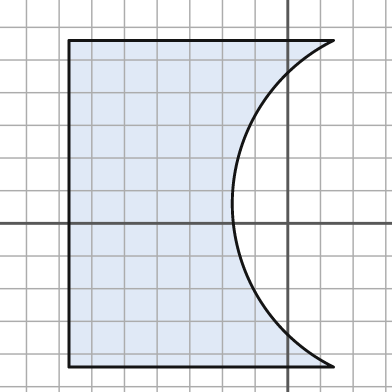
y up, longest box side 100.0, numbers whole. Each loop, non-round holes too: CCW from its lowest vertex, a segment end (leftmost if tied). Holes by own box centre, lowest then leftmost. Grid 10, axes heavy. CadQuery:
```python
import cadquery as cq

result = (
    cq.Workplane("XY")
    .moveTo(-67.0, -44.0)
    .lineTo(14.0, -44.0)
    .threePointArc((-17.0, 6.0), (14.0, 56.0))
    .lineTo(-67.0, 56.0)
    .close()
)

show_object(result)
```